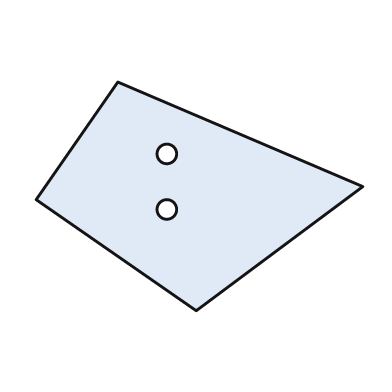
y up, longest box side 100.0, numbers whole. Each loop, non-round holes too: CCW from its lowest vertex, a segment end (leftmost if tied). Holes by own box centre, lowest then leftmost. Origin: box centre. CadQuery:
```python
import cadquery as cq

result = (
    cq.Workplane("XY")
    .moveTo(-1.0, -35.0)
    .lineTo(50.0, 3.0)
    .lineTo(-25.0, 35.0)
    .lineTo(-50.0, -1.0)
    .close()
    .moveTo(-10.0, -4.0)
    .circle(3.0)
    .moveTo(-10.0, 13.0)
    .circle(3.0)
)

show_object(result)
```